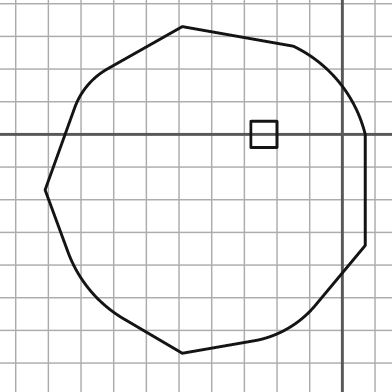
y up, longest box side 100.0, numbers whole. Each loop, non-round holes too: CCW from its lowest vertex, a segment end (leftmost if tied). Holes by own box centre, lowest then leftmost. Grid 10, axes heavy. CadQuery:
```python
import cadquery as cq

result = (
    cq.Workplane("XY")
    .moveTo(-49.0, -67.0)
    .lineTo(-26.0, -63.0)
    .threePointArc((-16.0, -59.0), (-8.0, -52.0))
    .lineTo(7.0, -34.0)
    .lineTo(7.0, 0.0)
    .threePointArc((-1.0, 16.0), (-15.0, 27.0))
    .lineTo(-49.0, 33.0)
    .lineTo(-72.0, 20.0)
    .threePointArc((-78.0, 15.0), (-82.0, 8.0))
    .lineTo(-91.0, -17.0)
    .lineTo(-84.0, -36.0)
    .threePointArc((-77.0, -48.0), (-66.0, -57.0))
    .close()
    .moveTo(-28.0, -4.0)
    .lineTo(-20.0, -4.0)
    .lineTo(-20.0, 4.0)
    .lineTo(-28.0, 4.0)
    .close()
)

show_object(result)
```